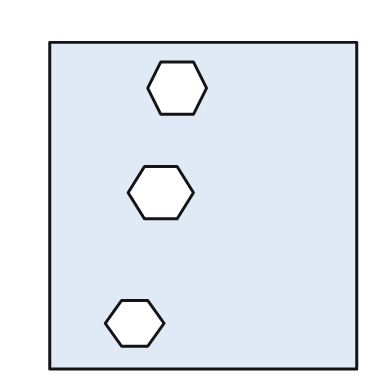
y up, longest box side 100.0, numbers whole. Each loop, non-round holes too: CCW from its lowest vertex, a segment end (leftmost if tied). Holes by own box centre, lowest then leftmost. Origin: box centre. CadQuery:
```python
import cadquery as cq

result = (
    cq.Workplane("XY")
    .moveTo(-47.0, -50.0)
    .lineTo(47.0, -50.0)
    .lineTo(47.0, 50.0)
    .lineTo(-47.0, 50.0)
    .close()
    .moveTo(-25.0, -43.0)
    .lineTo(-17.0, -43.0)
    .lineTo(-12.0, -36.0)
    .lineTo(-17.0, -29.0)
    .lineTo(-25.0, -29.0)
    .lineTo(-30.0, -36.0)
    .close()
    .moveTo(-18.0, -4.0)
    .lineTo(-8.0, -4.0)
    .lineTo(-3.0, 4.0)
    .lineTo(-8.0, 12.0)
    .lineTo(-18.0, 12.0)
    .lineTo(-23.0, 4.0)
    .close()
    .moveTo(-13.0, 28.0)
    .lineTo(-3.0, 28.0)
    .lineTo(1.0, 36.0)
    .lineTo(-3.0, 44.0)
    .lineTo(-13.0, 44.0)
    .lineTo(-17.0, 36.0)
    .close()
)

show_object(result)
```